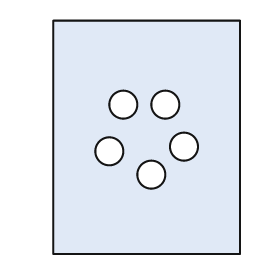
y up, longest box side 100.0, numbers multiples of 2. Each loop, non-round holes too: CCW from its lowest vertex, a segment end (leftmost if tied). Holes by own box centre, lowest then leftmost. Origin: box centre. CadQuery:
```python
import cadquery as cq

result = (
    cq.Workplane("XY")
    .moveTo(-40.0, -50.0)
    .lineTo(40.0, -50.0)
    .lineTo(40.0, 50.0)
    .lineTo(-40.0, 50.0)
    .close()
    .moveTo(2.0, -16.0)
    .circle(6.0)
    .moveTo(-16.0, -6.0)
    .circle(6.0)
    .moveTo(16.0, -4.0)
    .circle(6.0)
    .moveTo(-10.0, 14.0)
    .circle(6.0)
    .moveTo(8.0, 14.0)
    .circle(6.0)
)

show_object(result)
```